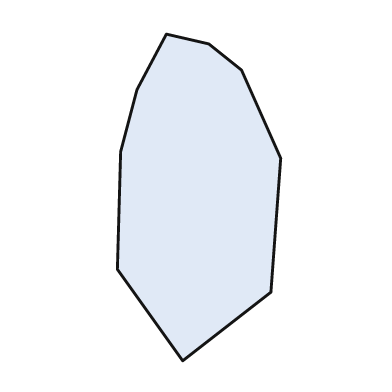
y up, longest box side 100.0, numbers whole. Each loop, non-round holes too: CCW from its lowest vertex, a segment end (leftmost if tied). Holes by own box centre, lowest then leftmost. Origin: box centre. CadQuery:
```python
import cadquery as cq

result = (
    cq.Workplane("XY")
    .moveTo(-5.0, -50.0)
    .lineTo(22.0, -29.0)
    .lineTo(25.0, 12.0)
    .lineTo(13.0, 39.0)
    .lineTo(3.0, 47.0)
    .lineTo(-10.0, 50.0)
    .lineTo(-19.0, 33.0)
    .lineTo(-24.0, 14.0)
    .lineTo(-25.0, -22.0)
    .close()
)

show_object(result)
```